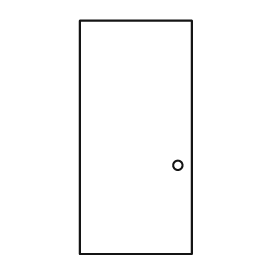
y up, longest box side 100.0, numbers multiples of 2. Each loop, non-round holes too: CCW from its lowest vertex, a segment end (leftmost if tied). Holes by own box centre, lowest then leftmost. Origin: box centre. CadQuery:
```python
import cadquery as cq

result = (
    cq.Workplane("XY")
    .moveTo(-24.0, -50.0)
    .lineTo(24.0, -50.0)
    .lineTo(24.0, 50.0)
    .lineTo(-24.0, 50.0)
    .close()
    .moveTo(18.0, -12.0)
    .circle(2.0)
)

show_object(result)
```